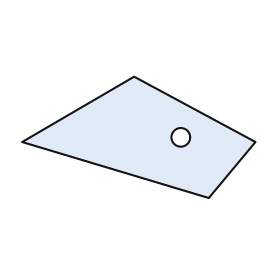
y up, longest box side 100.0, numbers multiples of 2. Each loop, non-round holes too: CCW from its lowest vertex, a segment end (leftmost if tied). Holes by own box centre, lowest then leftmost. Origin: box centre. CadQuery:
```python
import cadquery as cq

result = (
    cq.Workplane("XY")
    .moveTo(30.0, -26.0)
    .lineTo(50.0, -2.0)
    .lineTo(-2.0, 26.0)
    .lineTo(-50.0, -2.0)
    .close()
    .moveTo(18.0, 0.0)
    .circle(4.0)
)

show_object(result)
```